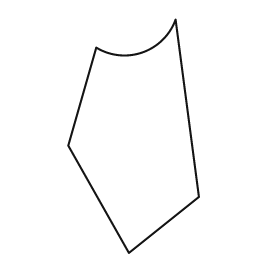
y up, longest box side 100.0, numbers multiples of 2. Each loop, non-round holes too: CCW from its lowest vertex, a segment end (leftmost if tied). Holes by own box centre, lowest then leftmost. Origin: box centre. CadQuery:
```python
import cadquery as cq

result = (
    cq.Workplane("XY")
    .moveTo(-2.0, -50.0)
    .lineTo(28.0, -26.0)
    .lineTo(18.0, 50.0)
    .threePointArc((4.0, 36.0), (-16.0, 38.0))
    .lineTo(-28.0, -4.0)
    .close()
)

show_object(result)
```